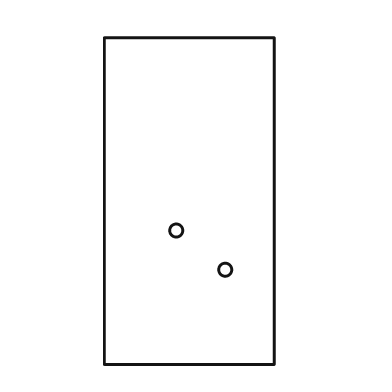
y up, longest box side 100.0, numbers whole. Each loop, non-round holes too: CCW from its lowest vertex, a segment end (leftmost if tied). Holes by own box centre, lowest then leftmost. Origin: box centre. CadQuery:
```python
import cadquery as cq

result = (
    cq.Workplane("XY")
    .moveTo(-26.0, -50.0)
    .lineTo(26.0, -50.0)
    .lineTo(26.0, 50.0)
    .lineTo(-26.0, 50.0)
    .close()
    .moveTo(11.0, -21.0)
    .circle(2.0)
    .moveTo(-4.0, -9.0)
    .circle(2.0)
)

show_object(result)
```